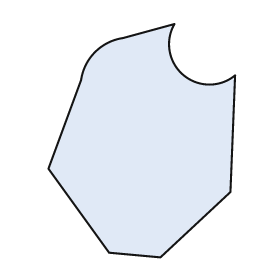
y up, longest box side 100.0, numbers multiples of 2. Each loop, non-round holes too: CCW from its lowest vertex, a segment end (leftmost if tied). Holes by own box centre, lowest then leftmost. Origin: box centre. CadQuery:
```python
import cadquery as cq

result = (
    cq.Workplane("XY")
    .moveTo(8.0, -50.0)
    .lineTo(38.0, -22.0)
    .lineTo(40.0, 28.0)
    .threePointArc((18.0, 28.0), (14.0, 50.0))
    .lineTo(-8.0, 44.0)
    .threePointArc((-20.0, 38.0), (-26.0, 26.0))
    .lineTo(-40.0, -12.0)
    .lineTo(-14.0, -48.0)
    .close()
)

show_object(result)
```